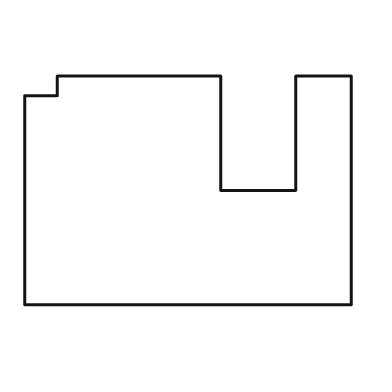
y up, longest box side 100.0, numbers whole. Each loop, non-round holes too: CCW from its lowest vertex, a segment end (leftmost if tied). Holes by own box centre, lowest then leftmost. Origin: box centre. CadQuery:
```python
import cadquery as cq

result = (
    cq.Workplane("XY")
    .moveTo(-50.0, -35.0)
    .lineTo(50.0, -35.0)
    .lineTo(50.0, 35.0)
    .lineTo(33.0, 35.0)
    .lineTo(33.0, 0.0)
    .lineTo(10.0, 0.0)
    .lineTo(10.0, 35.0)
    .lineTo(-40.0, 35.0)
    .lineTo(-40.0, 29.0)
    .lineTo(-50.0, 29.0)
    .close()
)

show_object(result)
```